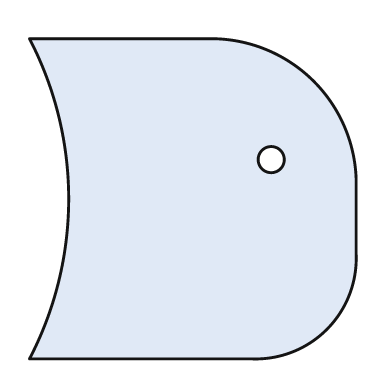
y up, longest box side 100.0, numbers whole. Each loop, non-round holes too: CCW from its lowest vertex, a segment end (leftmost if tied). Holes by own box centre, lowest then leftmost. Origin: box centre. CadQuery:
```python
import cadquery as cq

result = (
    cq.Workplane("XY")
    .moveTo(-50.0, -49.0)
    .lineTo(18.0, -49.0)
    .threePointArc((41.0, -40.0), (50.0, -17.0))
    .lineTo(50.0, 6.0)
    .threePointArc((37.0, 36.0), (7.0, 49.0))
    .lineTo(-50.0, 49.0)
    .threePointArc((-38.0, 0.0), (-50.0, -49.0))
    .close()
    .moveTo(24.0, 12.0)
    .circle(4.0)
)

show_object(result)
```